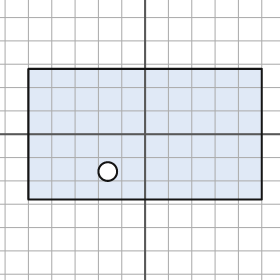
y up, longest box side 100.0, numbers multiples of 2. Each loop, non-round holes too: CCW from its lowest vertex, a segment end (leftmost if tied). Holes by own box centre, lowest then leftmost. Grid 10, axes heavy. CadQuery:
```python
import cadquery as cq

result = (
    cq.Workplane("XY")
    .moveTo(-50.0, -28.0)
    .lineTo(50.0, -28.0)
    .lineTo(50.0, 28.0)
    .lineTo(-50.0, 28.0)
    .close()
    .moveTo(-16.0, -16.0)
    .circle(4.0)
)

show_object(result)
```